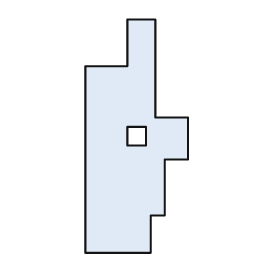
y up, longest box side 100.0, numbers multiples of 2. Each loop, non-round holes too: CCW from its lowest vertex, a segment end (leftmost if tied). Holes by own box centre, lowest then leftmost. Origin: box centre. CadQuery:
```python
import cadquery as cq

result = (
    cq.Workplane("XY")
    .moveTo(-22.0, -50.0)
    .lineTo(6.0, -50.0)
    .lineTo(6.0, -34.0)
    .lineTo(12.0, -34.0)
    .lineTo(12.0, -10.0)
    .lineTo(22.0, -10.0)
    .lineTo(22.0, 8.0)
    .lineTo(8.0, 8.0)
    .lineTo(8.0, 50.0)
    .lineTo(-4.0, 50.0)
    .lineTo(-4.0, 30.0)
    .lineTo(-22.0, 30.0)
    .close()
    .moveTo(-4.0, -4.0)
    .lineTo(4.0, -4.0)
    .lineTo(4.0, 4.0)
    .lineTo(-4.0, 4.0)
    .close()
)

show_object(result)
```